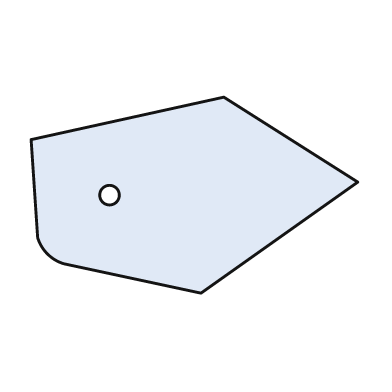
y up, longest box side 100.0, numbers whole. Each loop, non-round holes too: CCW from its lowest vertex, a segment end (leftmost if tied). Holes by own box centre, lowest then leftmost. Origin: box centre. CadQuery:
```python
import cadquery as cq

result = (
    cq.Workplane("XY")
    .moveTo(2.0, -30.0)
    .lineTo(50.0, 4.0)
    .lineTo(9.0, 30.0)
    .lineTo(-50.0, 17.0)
    .lineTo(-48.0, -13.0)
    .threePointArc((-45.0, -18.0), (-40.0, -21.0))
    .close()
    .moveTo(-26.0, 0.0)
    .circle(3.0)
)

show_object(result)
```